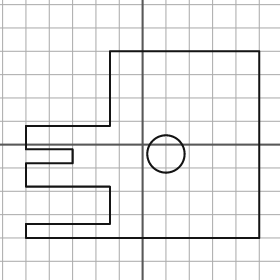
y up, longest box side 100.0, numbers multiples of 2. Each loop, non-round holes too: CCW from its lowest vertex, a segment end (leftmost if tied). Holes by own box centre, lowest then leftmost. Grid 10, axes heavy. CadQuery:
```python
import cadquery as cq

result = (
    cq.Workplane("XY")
    .moveTo(-50.0, -40.0)
    .lineTo(50.0, -40.0)
    .lineTo(50.0, 40.0)
    .lineTo(-14.0, 40.0)
    .lineTo(-14.0, 8.0)
    .lineTo(-50.0, 8.0)
    .lineTo(-50.0, -2.0)
    .lineTo(-30.0, -2.0)
    .lineTo(-30.0, -8.0)
    .lineTo(-50.0, -8.0)
    .lineTo(-50.0, -18.0)
    .lineTo(-14.0, -18.0)
    .lineTo(-14.0, -34.0)
    .lineTo(-50.0, -34.0)
    .close()
    .moveTo(10.0, -4.0)
    .circle(8.0)
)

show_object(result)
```